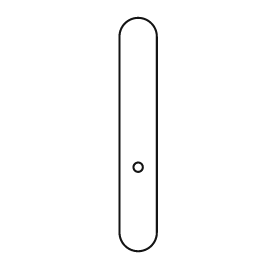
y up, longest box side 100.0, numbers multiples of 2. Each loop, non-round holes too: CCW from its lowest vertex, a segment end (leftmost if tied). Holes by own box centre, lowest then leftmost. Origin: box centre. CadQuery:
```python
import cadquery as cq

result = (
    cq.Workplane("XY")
    .moveTo(-8.0, -42.0)
    .threePointArc((0.0, -50.0), (8.0, -42.0))
    .lineTo(8.0, 42.0)
    .threePointArc((0.0, 50.0), (-8.0, 42.0))
    .close()
    .moveTo(0.0, -14.0)
    .circle(2.0)
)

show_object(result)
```